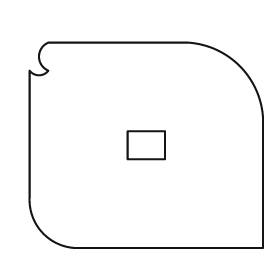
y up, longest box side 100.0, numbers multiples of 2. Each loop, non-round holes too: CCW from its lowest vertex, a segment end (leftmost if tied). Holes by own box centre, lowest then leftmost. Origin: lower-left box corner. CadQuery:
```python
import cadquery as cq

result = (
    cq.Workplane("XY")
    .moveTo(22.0, 0.0)
    .lineTo(100.0, 0.0)
    .lineTo(100.0, 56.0)
    .threePointArc((90.0, 78.0), (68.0, 88.0))
    .lineTo(8.0, 88.0)
    .threePointArc((4.0, 82.0), (8.0, 76.0))
    .threePointArc((4.0, 74.0), (0.0, 76.0))
    .lineTo(0.0, 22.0)
    .threePointArc((6.0, 6.0), (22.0, 0.0))
    .close()
    .moveTo(42.0, 38.0)
    .lineTo(58.0, 38.0)
    .lineTo(58.0, 50.0)
    .lineTo(42.0, 50.0)
    .close()
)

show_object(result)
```